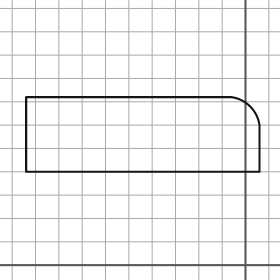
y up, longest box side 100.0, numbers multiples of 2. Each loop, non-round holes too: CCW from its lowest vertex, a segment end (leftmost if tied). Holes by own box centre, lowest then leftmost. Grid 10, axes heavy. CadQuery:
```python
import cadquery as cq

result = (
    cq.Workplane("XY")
    .moveTo(-94.0, 40.0)
    .lineTo(6.0, 40.0)
    .lineTo(6.0, 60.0)
    .threePointArc((2.0, 68.0), (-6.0, 72.0))
    .lineTo(-94.0, 72.0)
    .close()
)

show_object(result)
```